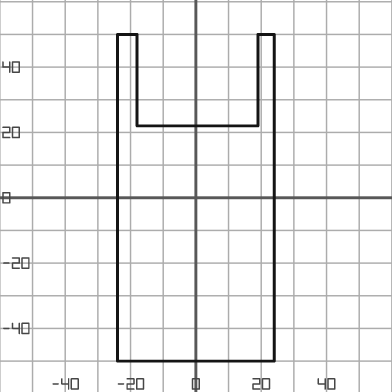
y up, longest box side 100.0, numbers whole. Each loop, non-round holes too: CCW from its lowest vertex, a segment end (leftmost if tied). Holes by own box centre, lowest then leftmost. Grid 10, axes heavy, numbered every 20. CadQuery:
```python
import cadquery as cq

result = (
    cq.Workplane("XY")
    .moveTo(-24.0, -50.0)
    .lineTo(24.0, -50.0)
    .lineTo(24.0, 50.0)
    .lineTo(19.0, 50.0)
    .lineTo(19.0, 22.0)
    .lineTo(-18.0, 22.0)
    .lineTo(-18.0, 50.0)
    .lineTo(-24.0, 50.0)
    .close()
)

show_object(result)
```